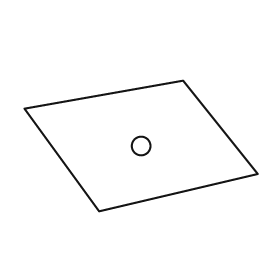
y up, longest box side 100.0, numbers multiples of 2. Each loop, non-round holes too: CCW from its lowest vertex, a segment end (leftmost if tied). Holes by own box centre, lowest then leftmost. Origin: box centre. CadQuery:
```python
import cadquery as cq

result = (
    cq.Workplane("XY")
    .moveTo(-18.0, -28.0)
    .lineTo(50.0, -12.0)
    .lineTo(18.0, 28.0)
    .lineTo(-50.0, 16.0)
    .close()
    .moveTo(0.0, 0.0)
    .circle(4.0)
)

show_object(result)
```